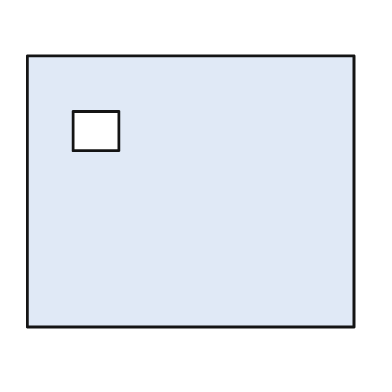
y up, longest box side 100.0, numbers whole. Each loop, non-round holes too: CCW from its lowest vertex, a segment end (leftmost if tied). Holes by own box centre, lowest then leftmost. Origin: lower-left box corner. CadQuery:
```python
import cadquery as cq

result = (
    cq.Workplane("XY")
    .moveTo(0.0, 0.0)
    .lineTo(100.0, 0.0)
    .lineTo(100.0, 83.0)
    .lineTo(0.0, 83.0)
    .close()
    .moveTo(14.0, 54.0)
    .lineTo(28.0, 54.0)
    .lineTo(28.0, 66.0)
    .lineTo(14.0, 66.0)
    .close()
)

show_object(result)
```